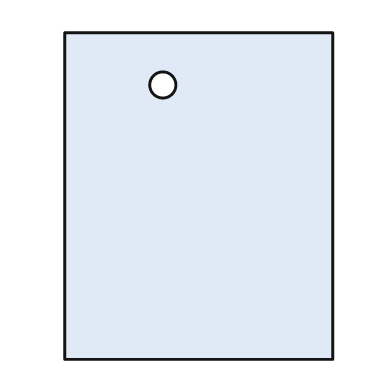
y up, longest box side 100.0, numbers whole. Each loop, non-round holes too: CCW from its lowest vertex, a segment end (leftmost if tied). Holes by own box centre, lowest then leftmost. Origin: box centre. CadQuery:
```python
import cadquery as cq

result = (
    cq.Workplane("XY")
    .moveTo(-41.0, -50.0)
    .lineTo(41.0, -50.0)
    .lineTo(41.0, 50.0)
    .lineTo(-41.0, 50.0)
    .close()
    .moveTo(-11.0, 34.0)
    .circle(4.0)
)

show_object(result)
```